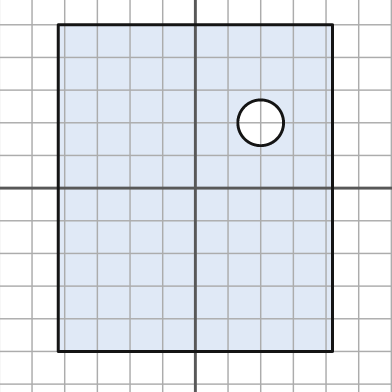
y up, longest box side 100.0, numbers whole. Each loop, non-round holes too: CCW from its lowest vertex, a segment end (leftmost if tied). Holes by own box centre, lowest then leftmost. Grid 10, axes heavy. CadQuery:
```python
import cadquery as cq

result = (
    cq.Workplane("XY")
    .moveTo(-42.0, -50.0)
    .lineTo(42.0, -50.0)
    .lineTo(42.0, 50.0)
    .lineTo(-42.0, 50.0)
    .close()
    .moveTo(20.0, 20.0)
    .circle(7.0)
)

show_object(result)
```